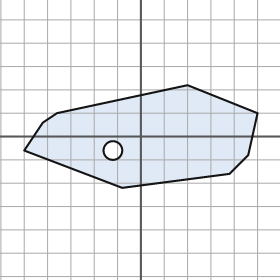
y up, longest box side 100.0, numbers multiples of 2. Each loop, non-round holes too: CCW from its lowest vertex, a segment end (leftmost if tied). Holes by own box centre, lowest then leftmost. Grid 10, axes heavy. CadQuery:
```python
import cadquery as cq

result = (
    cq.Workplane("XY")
    .moveTo(-8.0, -22.0)
    .lineTo(38.0, -16.0)
    .lineTo(46.0, -8.0)
    .lineTo(50.0, 10.0)
    .lineTo(20.0, 22.0)
    .lineTo(-36.0, 10.0)
    .lineTo(-42.0, 6.0)
    .lineTo(-50.0, -6.0)
    .close()
    .moveTo(-12.0, -6.0)
    .circle(4.0)
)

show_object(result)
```